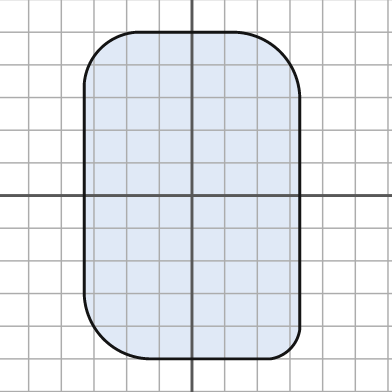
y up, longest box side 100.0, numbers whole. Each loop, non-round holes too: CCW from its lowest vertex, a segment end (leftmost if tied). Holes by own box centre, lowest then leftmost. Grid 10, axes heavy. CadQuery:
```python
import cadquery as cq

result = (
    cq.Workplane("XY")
    .moveTo(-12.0, -50.0)
    .lineTo(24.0, -50.0)
    .threePointArc((30.0, -47.0), (33.0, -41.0))
    .lineTo(33.0, 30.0)
    .threePointArc((27.0, 44.0), (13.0, 50.0))
    .lineTo(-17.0, 50.0)
    .threePointArc((-28.0, 45.0), (-33.0, 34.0))
    .lineTo(-33.0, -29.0)
    .threePointArc((-27.0, -44.0), (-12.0, -50.0))
    .close()
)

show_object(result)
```